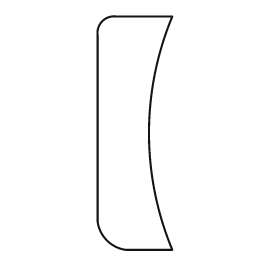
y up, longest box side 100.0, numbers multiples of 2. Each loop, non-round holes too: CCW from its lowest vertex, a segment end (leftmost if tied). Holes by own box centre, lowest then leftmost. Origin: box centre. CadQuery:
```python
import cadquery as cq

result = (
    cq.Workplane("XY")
    .moveTo(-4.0, -50.0)
    .lineTo(16.0, -50.0)
    .threePointArc((6.0, 0.0), (16.0, 50.0))
    .lineTo(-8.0, 50.0)
    .threePointArc((-14.0, 48.0), (-16.0, 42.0))
    .lineTo(-16.0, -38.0)
    .threePointArc((-12.0, -46.0), (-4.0, -50.0))
    .close()
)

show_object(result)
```